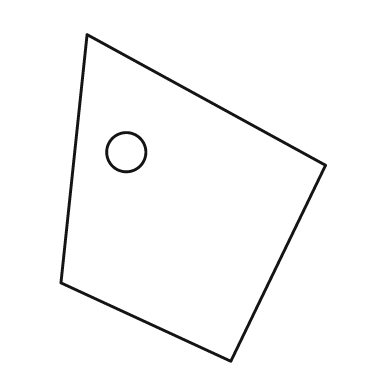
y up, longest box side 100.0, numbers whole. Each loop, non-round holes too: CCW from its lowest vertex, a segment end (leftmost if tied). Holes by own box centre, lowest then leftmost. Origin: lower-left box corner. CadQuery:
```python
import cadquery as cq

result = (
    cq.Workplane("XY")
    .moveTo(52.0, 0.0)
    .lineTo(81.0, 60.0)
    .lineTo(8.0, 100.0)
    .lineTo(0.0, 24.0)
    .close()
    .moveTo(20.0, 64.0)
    .circle(6.0)
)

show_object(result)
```